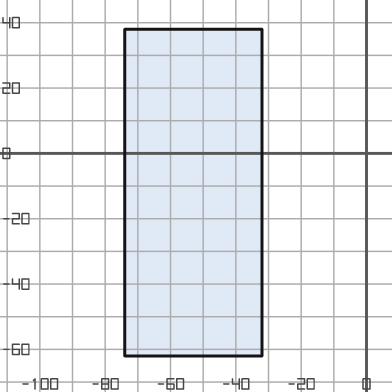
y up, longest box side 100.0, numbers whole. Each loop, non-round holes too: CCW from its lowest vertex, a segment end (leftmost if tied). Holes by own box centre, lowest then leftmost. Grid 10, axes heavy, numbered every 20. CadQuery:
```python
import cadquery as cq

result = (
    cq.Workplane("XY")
    .moveTo(-74.0, -62.0)
    .lineTo(-32.0, -62.0)
    .lineTo(-32.0, 38.0)
    .lineTo(-74.0, 38.0)
    .close()
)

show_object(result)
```